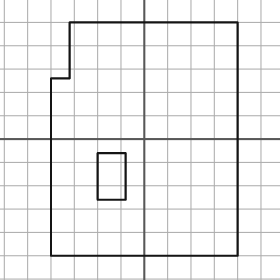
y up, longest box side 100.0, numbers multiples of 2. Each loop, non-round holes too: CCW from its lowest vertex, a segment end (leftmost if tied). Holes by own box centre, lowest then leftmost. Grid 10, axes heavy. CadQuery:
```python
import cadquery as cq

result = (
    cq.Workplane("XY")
    .moveTo(-40.0, -50.0)
    .lineTo(40.0, -50.0)
    .lineTo(40.0, 50.0)
    .lineTo(-32.0, 50.0)
    .lineTo(-32.0, 26.0)
    .lineTo(-40.0, 26.0)
    .close()
    .moveTo(-20.0, -26.0)
    .lineTo(-8.0, -26.0)
    .lineTo(-8.0, -6.0)
    .lineTo(-20.0, -6.0)
    .close()
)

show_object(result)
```